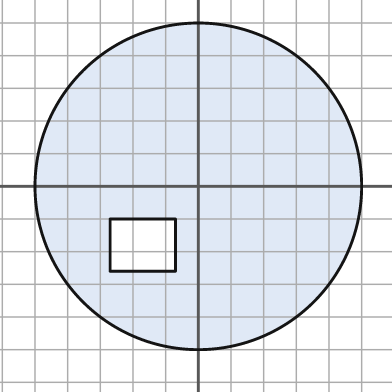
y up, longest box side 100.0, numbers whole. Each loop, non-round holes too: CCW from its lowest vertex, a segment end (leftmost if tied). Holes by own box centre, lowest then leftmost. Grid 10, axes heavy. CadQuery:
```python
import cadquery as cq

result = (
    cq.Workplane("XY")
    .moveTo(0.0, 0.0)
    .circle(50.0)
    .moveTo(-27.0, -26.0)
    .lineTo(-7.0, -26.0)
    .lineTo(-7.0, -10.0)
    .lineTo(-27.0, -10.0)
    .close()
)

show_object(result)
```